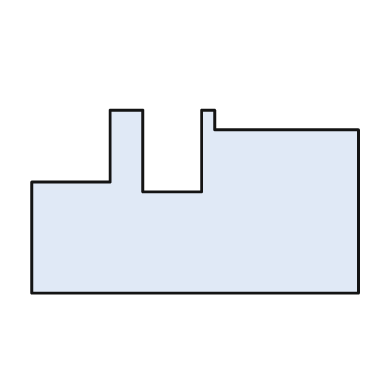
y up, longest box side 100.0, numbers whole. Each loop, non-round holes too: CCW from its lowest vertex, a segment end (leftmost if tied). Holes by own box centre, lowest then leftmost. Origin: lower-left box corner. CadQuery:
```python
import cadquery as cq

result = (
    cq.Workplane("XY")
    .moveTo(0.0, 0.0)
    .lineTo(100.0, 0.0)
    .lineTo(100.0, 50.0)
    .lineTo(56.0, 50.0)
    .lineTo(56.0, 56.0)
    .lineTo(52.0, 56.0)
    .lineTo(52.0, 31.0)
    .lineTo(34.0, 31.0)
    .lineTo(34.0, 56.0)
    .lineTo(24.0, 56.0)
    .lineTo(24.0, 34.0)
    .lineTo(0.0, 34.0)
    .close()
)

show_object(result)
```